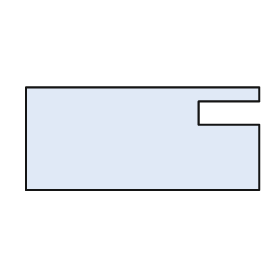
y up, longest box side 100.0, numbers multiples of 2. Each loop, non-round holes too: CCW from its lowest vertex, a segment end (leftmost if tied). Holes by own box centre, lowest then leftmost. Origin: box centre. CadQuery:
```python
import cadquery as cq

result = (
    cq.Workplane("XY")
    .moveTo(-50.0, -22.0)
    .lineTo(50.0, -22.0)
    .lineTo(50.0, 6.0)
    .lineTo(24.0, 6.0)
    .lineTo(24.0, 16.0)
    .lineTo(50.0, 16.0)
    .lineTo(50.0, 22.0)
    .lineTo(-50.0, 22.0)
    .close()
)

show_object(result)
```